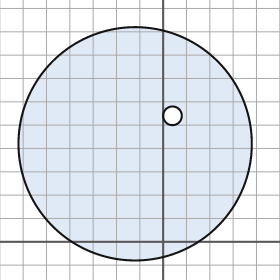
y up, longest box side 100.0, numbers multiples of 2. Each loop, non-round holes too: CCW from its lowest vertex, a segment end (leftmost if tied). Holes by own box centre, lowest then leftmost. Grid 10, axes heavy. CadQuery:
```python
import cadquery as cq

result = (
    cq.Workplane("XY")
    .moveTo(-12.0, 42.0)
    .circle(50.0)
    .moveTo(4.0, 54.0)
    .circle(4.0)
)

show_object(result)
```